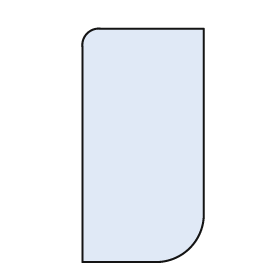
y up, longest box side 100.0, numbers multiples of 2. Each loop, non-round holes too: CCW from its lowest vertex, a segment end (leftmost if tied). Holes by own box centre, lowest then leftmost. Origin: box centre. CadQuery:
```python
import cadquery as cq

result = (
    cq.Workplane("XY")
    .moveTo(-26.0, -50.0)
    .lineTo(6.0, -50.0)
    .threePointArc((20.0, -44.0), (26.0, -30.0))
    .lineTo(26.0, 50.0)
    .lineTo(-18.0, 50.0)
    .threePointArc((-24.0, 48.0), (-26.0, 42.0))
    .close()
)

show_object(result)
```